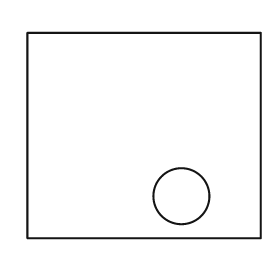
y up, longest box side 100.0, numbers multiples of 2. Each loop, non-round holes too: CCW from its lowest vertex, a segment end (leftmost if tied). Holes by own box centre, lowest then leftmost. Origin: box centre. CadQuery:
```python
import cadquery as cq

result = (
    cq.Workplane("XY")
    .moveTo(-50.0, -44.0)
    .lineTo(50.0, -44.0)
    .lineTo(50.0, 44.0)
    .lineTo(-50.0, 44.0)
    .close()
    .moveTo(16.0, -26.0)
    .circle(12.0)
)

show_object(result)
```